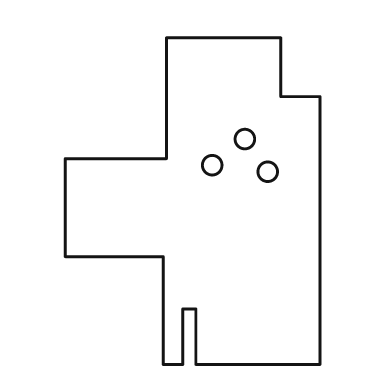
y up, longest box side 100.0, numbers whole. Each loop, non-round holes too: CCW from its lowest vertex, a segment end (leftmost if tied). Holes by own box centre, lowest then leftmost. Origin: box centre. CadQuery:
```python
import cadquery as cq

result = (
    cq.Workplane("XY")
    .moveTo(-9.0, -50.0)
    .lineTo(-3.0, -50.0)
    .lineTo(-3.0, -33.0)
    .lineTo(1.0, -33.0)
    .lineTo(1.0, -50.0)
    .lineTo(39.0, -50.0)
    .lineTo(39.0, 32.0)
    .lineTo(27.0, 32.0)
    .lineTo(27.0, 50.0)
    .lineTo(-8.0, 50.0)
    .lineTo(-8.0, 13.0)
    .lineTo(-39.0, 13.0)
    .lineTo(-39.0, -17.0)
    .lineTo(-9.0, -17.0)
    .close()
    .moveTo(23.0, 9.0)
    .circle(3.0)
    .moveTo(6.0, 11.0)
    .circle(3.0)
    .moveTo(16.0, 19.0)
    .circle(3.0)
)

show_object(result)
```